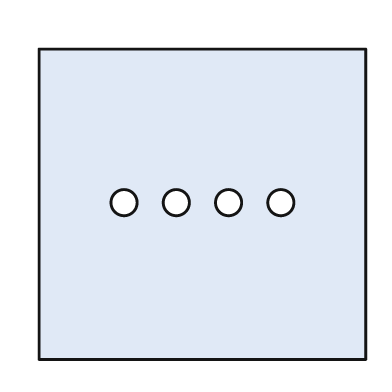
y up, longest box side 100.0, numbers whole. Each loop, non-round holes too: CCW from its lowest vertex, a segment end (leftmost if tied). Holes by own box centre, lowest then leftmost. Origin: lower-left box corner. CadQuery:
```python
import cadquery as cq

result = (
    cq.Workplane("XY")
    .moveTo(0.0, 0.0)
    .lineTo(100.0, 0.0)
    .lineTo(100.0, 95.0)
    .lineTo(0.0, 95.0)
    .close()
    .moveTo(26.0, 48.0)
    .circle(4.0)
    .moveTo(42.0, 48.0)
    .circle(4.0)
    .moveTo(58.0, 48.0)
    .circle(4.0)
    .moveTo(74.0, 48.0)
    .circle(4.0)
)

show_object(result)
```